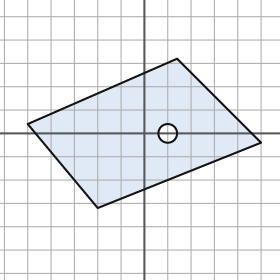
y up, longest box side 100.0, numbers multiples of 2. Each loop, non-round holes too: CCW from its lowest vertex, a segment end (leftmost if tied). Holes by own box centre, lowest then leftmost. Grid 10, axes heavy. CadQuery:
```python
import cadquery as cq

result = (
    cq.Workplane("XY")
    .moveTo(-20.0, -32.0)
    .lineTo(50.0, -4.0)
    .lineTo(14.0, 32.0)
    .lineTo(-50.0, 4.0)
    .close()
    .moveTo(10.0, 0.0)
    .circle(4.0)
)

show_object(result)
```